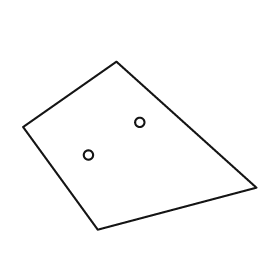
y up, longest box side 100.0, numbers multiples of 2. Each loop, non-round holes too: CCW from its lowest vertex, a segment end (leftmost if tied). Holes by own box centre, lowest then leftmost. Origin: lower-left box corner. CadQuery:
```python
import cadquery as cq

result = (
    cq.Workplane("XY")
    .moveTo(32.0, 0.0)
    .lineTo(100.0, 18.0)
    .lineTo(40.0, 72.0)
    .lineTo(0.0, 44.0)
    .close()
    .moveTo(28.0, 32.0)
    .circle(2.0)
    .moveTo(50.0, 46.0)
    .circle(2.0)
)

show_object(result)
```